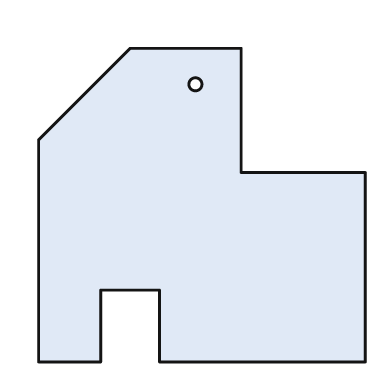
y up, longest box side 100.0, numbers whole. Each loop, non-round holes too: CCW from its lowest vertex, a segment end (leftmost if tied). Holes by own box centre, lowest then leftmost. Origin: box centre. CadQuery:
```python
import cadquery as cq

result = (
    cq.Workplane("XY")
    .moveTo(-50.0, -48.0)
    .lineTo(-31.0, -48.0)
    .lineTo(-31.0, -26.0)
    .lineTo(-13.0, -26.0)
    .lineTo(-13.0, -48.0)
    .lineTo(50.0, -48.0)
    .lineTo(50.0, 10.0)
    .lineTo(12.0, 10.0)
    .lineTo(12.0, 48.0)
    .lineTo(-22.0, 48.0)
    .lineTo(-50.0, 20.0)
    .close()
    .moveTo(-2.0, 37.0)
    .circle(2.0)
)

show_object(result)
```